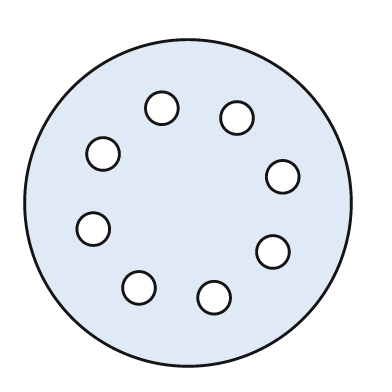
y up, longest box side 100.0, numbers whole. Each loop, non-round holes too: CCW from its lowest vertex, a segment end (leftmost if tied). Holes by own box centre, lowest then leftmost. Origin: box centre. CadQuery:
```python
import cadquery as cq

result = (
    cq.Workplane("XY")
    .moveTo(0.0, 0.0)
    .circle(50.0)
    .moveTo(8.0, -29.0)
    .circle(5.0)
    .moveTo(-15.0, -26.0)
    .circle(5.0)
    .moveTo(26.0, -15.0)
    .circle(5.0)
    .moveTo(-29.0, -8.0)
    .circle(5.0)
    .moveTo(29.0, 8.0)
    .circle(5.0)
    .moveTo(-26.0, 15.0)
    .circle(5.0)
    .moveTo(15.0, 26.0)
    .circle(5.0)
    .moveTo(-8.0, 29.0)
    .circle(5.0)
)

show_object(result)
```